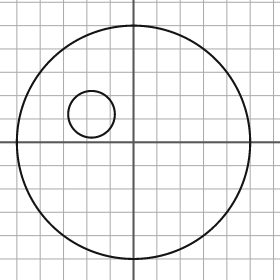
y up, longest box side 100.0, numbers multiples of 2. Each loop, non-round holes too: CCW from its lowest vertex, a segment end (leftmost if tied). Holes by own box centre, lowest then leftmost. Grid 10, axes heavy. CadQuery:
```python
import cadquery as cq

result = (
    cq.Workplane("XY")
    .moveTo(0.0, 0.0)
    .circle(50.0)
    .moveTo(-18.0, 12.0)
    .circle(10.0)
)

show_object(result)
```